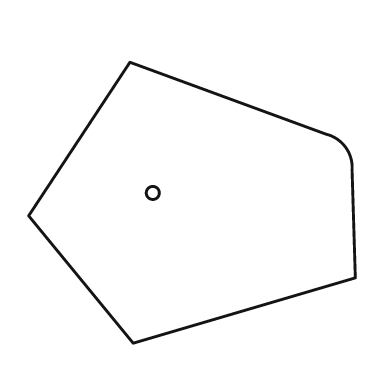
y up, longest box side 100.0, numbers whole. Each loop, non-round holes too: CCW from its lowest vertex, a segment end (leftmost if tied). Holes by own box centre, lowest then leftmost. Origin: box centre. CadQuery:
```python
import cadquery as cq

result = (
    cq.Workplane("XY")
    .moveTo(-18.0, -43.0)
    .lineTo(50.0, -23.0)
    .lineTo(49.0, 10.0)
    .threePointArc((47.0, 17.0), (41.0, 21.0))
    .lineTo(-19.0, 43.0)
    .lineTo(-50.0, -4.0)
    .close()
    .moveTo(-12.0, 3.0)
    .circle(2.0)
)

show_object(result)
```